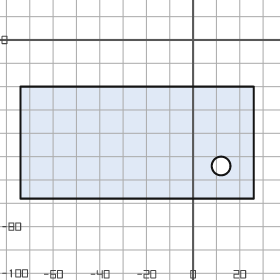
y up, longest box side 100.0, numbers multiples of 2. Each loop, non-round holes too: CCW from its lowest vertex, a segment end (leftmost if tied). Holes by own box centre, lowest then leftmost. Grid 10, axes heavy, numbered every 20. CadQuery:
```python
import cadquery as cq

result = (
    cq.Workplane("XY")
    .moveTo(-74.0, -68.0)
    .lineTo(26.0, -68.0)
    .lineTo(26.0, -20.0)
    .lineTo(-74.0, -20.0)
    .close()
    .moveTo(12.0, -54.0)
    .circle(4.0)
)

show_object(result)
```